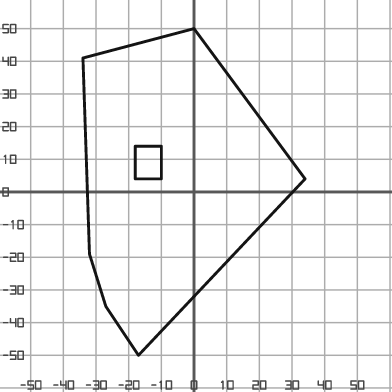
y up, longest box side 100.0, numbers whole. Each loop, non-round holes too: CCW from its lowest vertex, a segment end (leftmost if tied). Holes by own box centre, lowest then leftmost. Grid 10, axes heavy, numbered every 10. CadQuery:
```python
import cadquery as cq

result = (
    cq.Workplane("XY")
    .moveTo(-17.0, -50.0)
    .lineTo(34.0, 4.0)
    .lineTo(0.0, 50.0)
    .lineTo(-34.0, 41.0)
    .lineTo(-32.0, -19.0)
    .lineTo(-27.0, -35.0)
    .close()
    .moveTo(-18.0, 4.0)
    .lineTo(-10.0, 4.0)
    .lineTo(-10.0, 14.0)
    .lineTo(-18.0, 14.0)
    .close()
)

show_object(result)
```